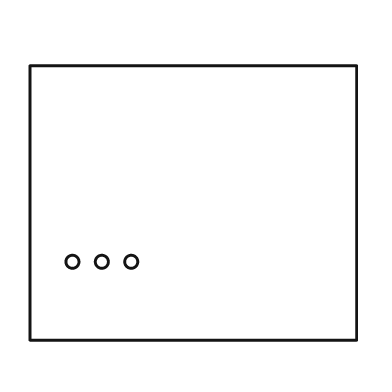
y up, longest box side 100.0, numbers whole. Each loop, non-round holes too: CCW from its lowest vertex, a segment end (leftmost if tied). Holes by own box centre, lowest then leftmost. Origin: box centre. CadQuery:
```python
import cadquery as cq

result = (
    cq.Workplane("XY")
    .moveTo(-50.0, -42.0)
    .lineTo(50.0, -42.0)
    .lineTo(50.0, 42.0)
    .lineTo(-50.0, 42.0)
    .close()
    .moveTo(-37.0, -18.0)
    .circle(2.0)
    .moveTo(-28.0, -18.0)
    .circle(2.0)
    .moveTo(-19.0, -18.0)
    .circle(2.0)
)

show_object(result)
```